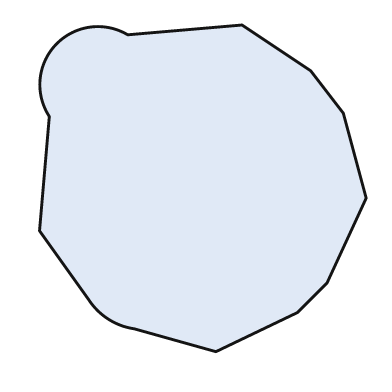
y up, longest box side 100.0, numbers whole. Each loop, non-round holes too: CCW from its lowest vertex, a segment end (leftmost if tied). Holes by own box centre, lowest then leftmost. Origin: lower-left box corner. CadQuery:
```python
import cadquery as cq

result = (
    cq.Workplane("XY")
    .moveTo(54.0, 0.0)
    .lineTo(79.0, 12.0)
    .lineTo(88.0, 21.0)
    .lineTo(100.0, 47.0)
    .lineTo(93.0, 73.0)
    .lineTo(83.0, 86.0)
    .lineTo(62.0, 100.0)
    .lineTo(27.0, 97.0)
    .threePointArc((5.0, 94.0), (3.0, 72.0))
    .lineTo(0.0, 37.0)
    .lineTo(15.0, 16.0)
    .threePointArc((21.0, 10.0), (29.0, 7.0))
    .close()
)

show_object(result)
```